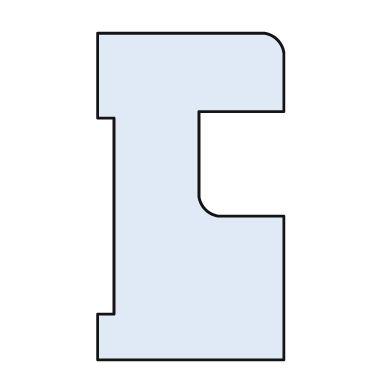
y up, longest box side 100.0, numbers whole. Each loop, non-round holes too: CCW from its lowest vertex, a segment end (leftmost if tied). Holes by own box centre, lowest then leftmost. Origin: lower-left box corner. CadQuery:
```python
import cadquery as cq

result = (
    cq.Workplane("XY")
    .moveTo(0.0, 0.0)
    .lineTo(57.0, 0.0)
    .lineTo(57.0, 44.0)
    .lineTo(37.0, 44.0)
    .threePointArc((33.0, 46.0), (31.0, 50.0))
    .lineTo(31.0, 76.0)
    .lineTo(57.0, 76.0)
    .lineTo(57.0, 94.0)
    .threePointArc((55.0, 98.0), (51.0, 100.0))
    .lineTo(0.0, 100.0)
    .lineTo(0.0, 74.0)
    .lineTo(5.0, 74.0)
    .lineTo(5.0, 14.0)
    .lineTo(0.0, 14.0)
    .close()
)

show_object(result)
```